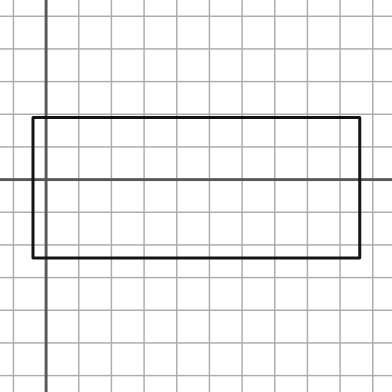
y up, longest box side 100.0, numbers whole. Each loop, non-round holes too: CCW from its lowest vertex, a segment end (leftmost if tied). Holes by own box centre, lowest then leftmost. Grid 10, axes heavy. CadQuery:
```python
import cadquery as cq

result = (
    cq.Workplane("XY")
    .moveTo(-4.0, -24.0)
    .lineTo(96.0, -24.0)
    .lineTo(96.0, 19.0)
    .lineTo(-4.0, 19.0)
    .close()
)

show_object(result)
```